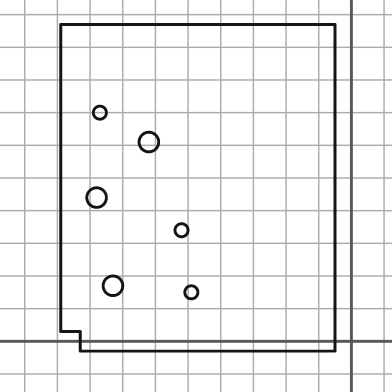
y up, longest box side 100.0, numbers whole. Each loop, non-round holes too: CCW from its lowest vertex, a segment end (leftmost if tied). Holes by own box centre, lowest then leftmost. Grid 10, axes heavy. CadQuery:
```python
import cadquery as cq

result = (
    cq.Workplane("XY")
    .moveTo(-83.0, -3.0)
    .lineTo(-5.0, -3.0)
    .lineTo(-5.0, 97.0)
    .lineTo(-89.0, 97.0)
    .lineTo(-89.0, 3.0)
    .lineTo(-83.0, 3.0)
    .close()
    .moveTo(-49.0, 15.0)
    .circle(2.0)
    .moveTo(-73.0, 17.0)
    .circle(3.0)
    .moveTo(-52.0, 34.0)
    .circle(2.0)
    .moveTo(-78.0, 44.0)
    .circle(3.0)
    .moveTo(-62.0, 61.0)
    .circle(3.0)
    .moveTo(-77.0, 70.0)
    .circle(2.0)
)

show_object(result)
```